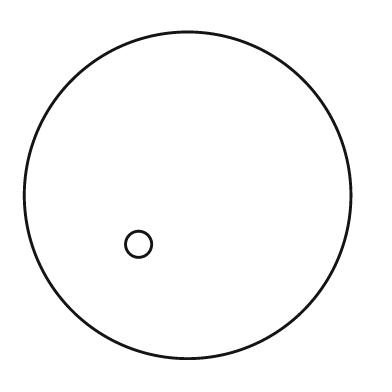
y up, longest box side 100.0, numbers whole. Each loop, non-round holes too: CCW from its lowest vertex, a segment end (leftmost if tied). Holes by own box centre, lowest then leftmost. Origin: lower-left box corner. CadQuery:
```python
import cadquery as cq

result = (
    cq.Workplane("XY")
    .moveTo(50.0, 50.0)
    .circle(50.0)
    .moveTo(35.0, 35.0)
    .circle(4.0)
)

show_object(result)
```